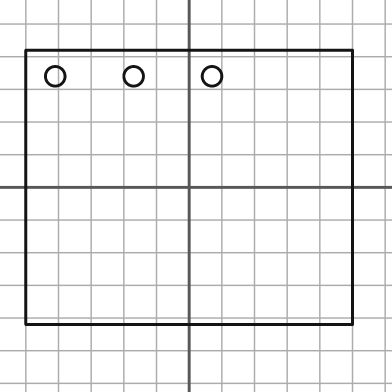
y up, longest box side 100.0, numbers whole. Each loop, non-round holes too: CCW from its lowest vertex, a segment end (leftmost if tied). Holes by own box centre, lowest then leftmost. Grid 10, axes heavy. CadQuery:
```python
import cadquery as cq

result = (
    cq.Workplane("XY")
    .moveTo(-50.0, -42.0)
    .lineTo(50.0, -42.0)
    .lineTo(50.0, 42.0)
    .lineTo(-50.0, 42.0)
    .close()
    .moveTo(-41.0, 34.0)
    .circle(3.0)
    .moveTo(-17.0, 34.0)
    .circle(3.0)
    .moveTo(7.0, 34.0)
    .circle(3.0)
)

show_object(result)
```